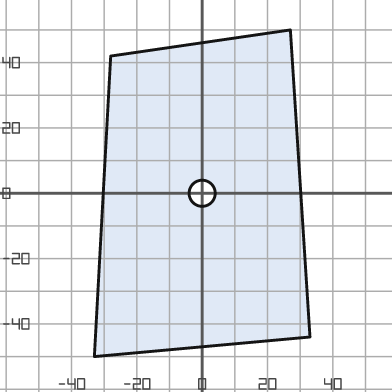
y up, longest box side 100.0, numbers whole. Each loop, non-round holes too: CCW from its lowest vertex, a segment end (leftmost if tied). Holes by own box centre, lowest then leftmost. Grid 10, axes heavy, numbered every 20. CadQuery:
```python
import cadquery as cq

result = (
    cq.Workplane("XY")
    .moveTo(-33.0, -50.0)
    .lineTo(33.0, -44.0)
    .lineTo(27.0, 50.0)
    .lineTo(-28.0, 42.0)
    .close()
    .moveTo(0.0, 0.0)
    .circle(4.0)
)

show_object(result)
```